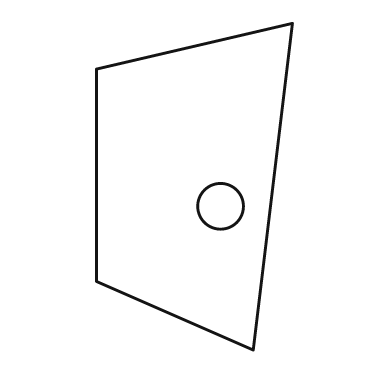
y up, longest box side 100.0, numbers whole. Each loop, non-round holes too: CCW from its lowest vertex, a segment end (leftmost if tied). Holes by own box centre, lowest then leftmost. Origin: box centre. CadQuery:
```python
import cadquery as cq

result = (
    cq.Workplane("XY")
    .moveTo(18.0, -50.0)
    .lineTo(30.0, 50.0)
    .lineTo(-30.0, 36.0)
    .lineTo(-30.0, -29.0)
    .close()
    .moveTo(8.0, -6.0)
    .circle(7.0)
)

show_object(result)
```